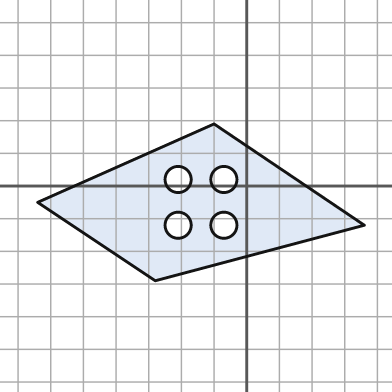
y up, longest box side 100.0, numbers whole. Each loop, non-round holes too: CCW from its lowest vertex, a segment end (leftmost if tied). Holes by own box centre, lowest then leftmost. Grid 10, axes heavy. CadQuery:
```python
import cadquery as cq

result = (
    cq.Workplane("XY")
    .moveTo(-28.0, -29.0)
    .lineTo(36.0, -12.0)
    .lineTo(-10.0, 19.0)
    .lineTo(-64.0, -5.0)
    .close()
    .moveTo(-21.0, -12.0)
    .circle(4.0)
    .moveTo(-7.0, -12.0)
    .circle(4.0)
    .moveTo(-21.0, 2.0)
    .circle(4.0)
    .moveTo(-7.0, 2.0)
    .circle(4.0)
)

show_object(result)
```